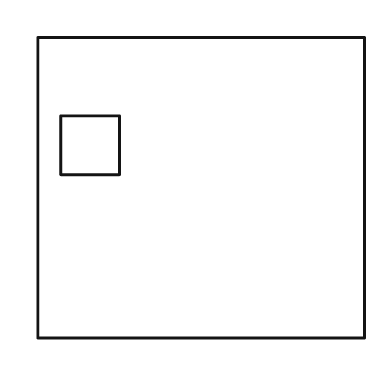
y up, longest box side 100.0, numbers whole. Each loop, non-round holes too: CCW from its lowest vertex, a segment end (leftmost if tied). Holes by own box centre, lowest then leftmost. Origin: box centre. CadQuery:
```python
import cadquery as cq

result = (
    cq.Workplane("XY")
    .moveTo(-50.0, -46.0)
    .lineTo(50.0, -46.0)
    .lineTo(50.0, 46.0)
    .lineTo(-50.0, 46.0)
    .close()
    .moveTo(-43.0, 4.0)
    .lineTo(-25.0, 4.0)
    .lineTo(-25.0, 22.0)
    .lineTo(-43.0, 22.0)
    .close()
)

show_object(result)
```